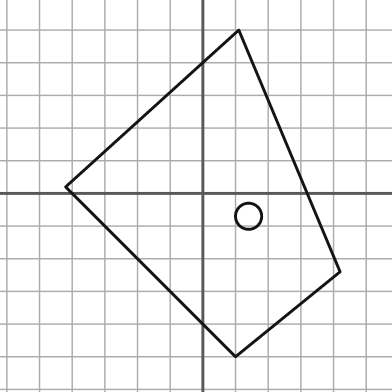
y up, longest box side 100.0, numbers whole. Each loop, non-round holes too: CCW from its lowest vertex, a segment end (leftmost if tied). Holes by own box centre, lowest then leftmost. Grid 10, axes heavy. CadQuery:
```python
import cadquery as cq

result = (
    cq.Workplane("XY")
    .moveTo(10.0, -50.0)
    .lineTo(42.0, -24.0)
    .lineTo(11.0, 50.0)
    .lineTo(-42.0, 2.0)
    .close()
    .moveTo(14.0, -7.0)
    .circle(4.0)
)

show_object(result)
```